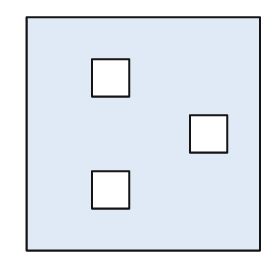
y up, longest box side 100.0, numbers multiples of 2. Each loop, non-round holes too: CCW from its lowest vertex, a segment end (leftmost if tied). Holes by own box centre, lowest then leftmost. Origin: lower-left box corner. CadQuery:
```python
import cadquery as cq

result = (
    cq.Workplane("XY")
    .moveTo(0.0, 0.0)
    .lineTo(100.0, 0.0)
    .lineTo(100.0, 100.0)
    .lineTo(0.0, 100.0)
    .close()
    .moveTo(28.0, 18.0)
    .lineTo(44.0, 18.0)
    .lineTo(44.0, 34.0)
    .lineTo(28.0, 34.0)
    .close()
    .moveTo(70.0, 42.0)
    .lineTo(86.0, 42.0)
    .lineTo(86.0, 58.0)
    .lineTo(70.0, 58.0)
    .close()
    .moveTo(28.0, 66.0)
    .lineTo(44.0, 66.0)
    .lineTo(44.0, 82.0)
    .lineTo(28.0, 82.0)
    .close()
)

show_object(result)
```